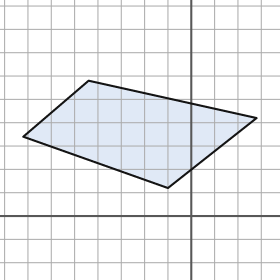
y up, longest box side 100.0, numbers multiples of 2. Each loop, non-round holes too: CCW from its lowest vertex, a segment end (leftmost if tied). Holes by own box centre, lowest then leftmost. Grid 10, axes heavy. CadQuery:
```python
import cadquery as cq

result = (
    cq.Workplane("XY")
    .moveTo(-10.0, 12.0)
    .lineTo(28.0, 42.0)
    .lineTo(-44.0, 58.0)
    .lineTo(-72.0, 34.0)
    .close()
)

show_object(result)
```